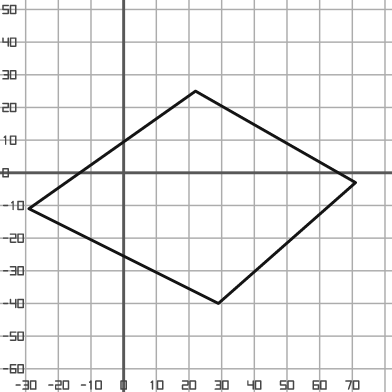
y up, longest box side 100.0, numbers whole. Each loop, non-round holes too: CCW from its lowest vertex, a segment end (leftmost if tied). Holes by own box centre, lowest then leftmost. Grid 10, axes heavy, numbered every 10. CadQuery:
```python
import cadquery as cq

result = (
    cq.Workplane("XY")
    .moveTo(29.0, -40.0)
    .lineTo(71.0, -3.0)
    .lineTo(22.0, 25.0)
    .lineTo(-29.0, -11.0)
    .close()
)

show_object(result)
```